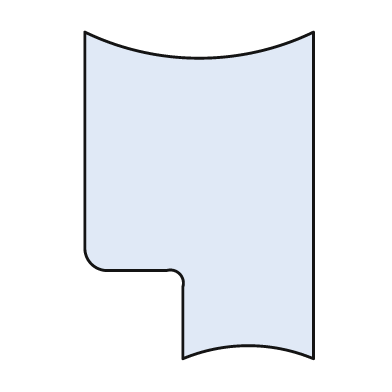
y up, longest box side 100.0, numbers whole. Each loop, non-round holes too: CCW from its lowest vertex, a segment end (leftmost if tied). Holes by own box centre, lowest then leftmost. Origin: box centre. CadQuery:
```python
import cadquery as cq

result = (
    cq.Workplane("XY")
    .moveTo(-5.0, -50.0)
    .threePointArc((15.0, -46.0), (35.0, -50.0))
    .lineTo(35.0, 50.0)
    .threePointArc((0.0, 42.0), (-35.0, 50.0))
    .lineTo(-35.0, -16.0)
    .threePointArc((-33.0, -21.0), (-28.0, -23.0))
    .lineTo(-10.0, -23.0)
    .threePointArc((-6.0, -24.0), (-5.0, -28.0))
    .close()
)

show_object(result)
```